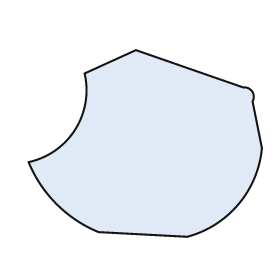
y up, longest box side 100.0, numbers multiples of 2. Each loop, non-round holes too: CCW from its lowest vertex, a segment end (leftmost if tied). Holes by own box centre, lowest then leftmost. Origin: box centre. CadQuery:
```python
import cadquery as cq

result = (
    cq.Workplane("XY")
    .moveTo(18.0, -40.0)
    .threePointArc((40.0, -26.0), (50.0, -2.0))
    .lineTo(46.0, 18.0)
    .threePointArc((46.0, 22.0), (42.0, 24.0))
    .lineTo(-4.0, 40.0)
    .lineTo(-26.0, 30.0)
    .threePointArc((-30.0, 6.0), (-50.0, -8.0))
    .threePointArc((-38.0, -26.0), (-20.0, -38.0))
    .close()
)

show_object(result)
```